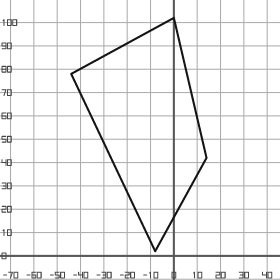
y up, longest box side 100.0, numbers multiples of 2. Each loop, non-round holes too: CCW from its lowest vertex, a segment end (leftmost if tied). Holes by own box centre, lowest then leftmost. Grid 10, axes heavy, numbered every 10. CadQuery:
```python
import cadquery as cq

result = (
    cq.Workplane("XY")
    .moveTo(-8.0, 2.0)
    .lineTo(14.0, 42.0)
    .lineTo(0.0, 102.0)
    .lineTo(-44.0, 78.0)
    .close()
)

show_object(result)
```